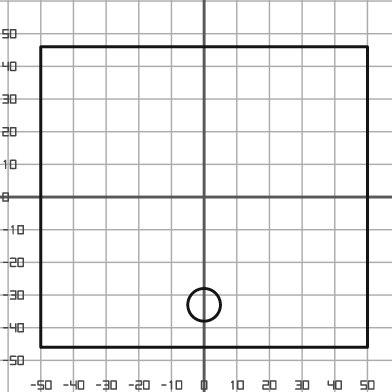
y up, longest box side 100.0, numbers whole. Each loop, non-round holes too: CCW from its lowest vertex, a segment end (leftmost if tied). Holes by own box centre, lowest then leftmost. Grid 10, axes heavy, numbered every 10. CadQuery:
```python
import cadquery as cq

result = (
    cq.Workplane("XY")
    .moveTo(-50.0, -46.0)
    .lineTo(50.0, -46.0)
    .lineTo(50.0, 46.0)
    .lineTo(-50.0, 46.0)
    .close()
    .moveTo(0.0, -33.0)
    .circle(5.0)
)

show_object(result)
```